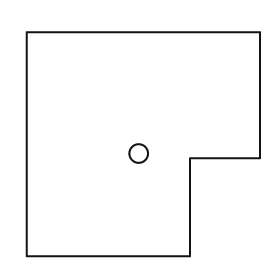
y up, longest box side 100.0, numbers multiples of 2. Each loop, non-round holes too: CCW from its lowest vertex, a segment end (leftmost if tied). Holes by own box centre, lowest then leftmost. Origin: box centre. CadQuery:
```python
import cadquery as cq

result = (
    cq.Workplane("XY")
    .moveTo(-50.0, -48.0)
    .lineTo(20.0, -48.0)
    .lineTo(20.0, -6.0)
    .lineTo(50.0, -6.0)
    .lineTo(50.0, 48.0)
    .lineTo(-50.0, 48.0)
    .close()
    .moveTo(-2.0, -4.0)
    .circle(4.0)
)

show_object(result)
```